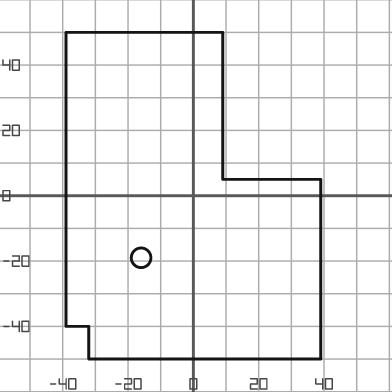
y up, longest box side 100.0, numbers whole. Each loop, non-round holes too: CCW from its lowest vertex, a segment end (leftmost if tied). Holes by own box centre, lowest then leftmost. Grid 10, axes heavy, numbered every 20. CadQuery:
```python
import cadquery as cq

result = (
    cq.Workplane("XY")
    .moveTo(-32.0, -50.0)
    .lineTo(39.0, -50.0)
    .lineTo(39.0, 5.0)
    .lineTo(9.0, 5.0)
    .lineTo(9.0, 50.0)
    .lineTo(-39.0, 50.0)
    .lineTo(-39.0, -40.0)
    .lineTo(-32.0, -40.0)
    .close()
    .moveTo(-16.0, -19.0)
    .circle(3.0)
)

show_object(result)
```